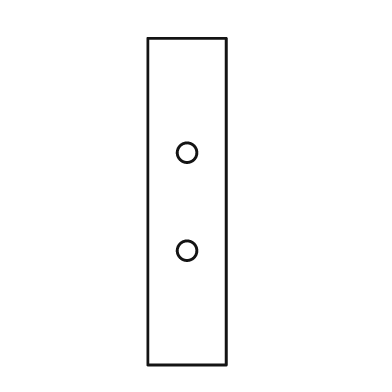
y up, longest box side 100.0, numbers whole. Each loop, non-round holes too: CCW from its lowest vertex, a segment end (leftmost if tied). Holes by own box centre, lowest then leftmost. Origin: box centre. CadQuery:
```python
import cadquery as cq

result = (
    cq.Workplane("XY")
    .moveTo(-12.0, -50.0)
    .lineTo(12.0, -50.0)
    .lineTo(12.0, 50.0)
    .lineTo(-12.0, 50.0)
    .close()
    .moveTo(0.0, -15.0)
    .circle(3.0)
    .moveTo(0.0, 15.0)
    .circle(3.0)
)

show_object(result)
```